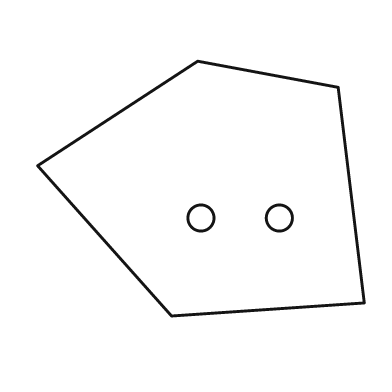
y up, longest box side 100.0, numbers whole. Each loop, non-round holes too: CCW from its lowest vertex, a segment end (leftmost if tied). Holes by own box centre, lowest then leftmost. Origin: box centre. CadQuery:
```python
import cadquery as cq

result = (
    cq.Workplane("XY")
    .moveTo(-9.0, -39.0)
    .lineTo(50.0, -35.0)
    .lineTo(42.0, 31.0)
    .lineTo(-1.0, 39.0)
    .lineTo(-50.0, 7.0)
    .close()
    .moveTo(0.0, -9.0)
    .circle(4.0)
    .moveTo(24.0, -9.0)
    .circle(4.0)
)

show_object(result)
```